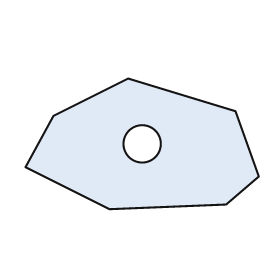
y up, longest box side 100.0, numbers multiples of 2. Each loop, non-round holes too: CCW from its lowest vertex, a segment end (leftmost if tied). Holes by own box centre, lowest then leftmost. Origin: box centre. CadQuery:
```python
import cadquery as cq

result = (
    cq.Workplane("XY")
    .moveTo(-14.0, -28.0)
    .lineTo(36.0, -26.0)
    .lineTo(50.0, -14.0)
    .lineTo(40.0, 14.0)
    .lineTo(-6.0, 28.0)
    .lineTo(-38.0, 12.0)
    .lineTo(-50.0, -10.0)
    .close()
    .moveTo(0.0, 0.0)
    .circle(8.0)
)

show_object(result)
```